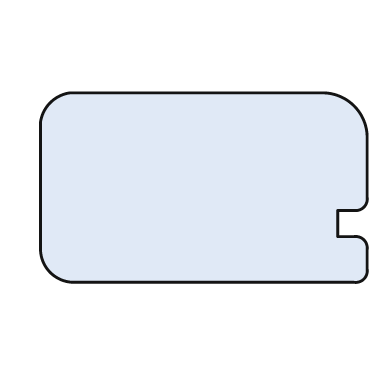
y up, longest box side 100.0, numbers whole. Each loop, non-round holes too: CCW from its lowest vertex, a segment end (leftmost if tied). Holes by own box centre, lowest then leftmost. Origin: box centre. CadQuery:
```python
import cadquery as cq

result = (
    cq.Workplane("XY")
    .moveTo(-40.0, -29.0)
    .lineTo(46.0, -29.0)
    .threePointArc((49.0, -28.0), (50.0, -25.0))
    .lineTo(50.0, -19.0)
    .threePointArc((49.0, -16.0), (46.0, -15.0))
    .lineTo(41.0, -15.0)
    .lineTo(41.0, -7.0)
    .lineTo(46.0, -7.0)
    .threePointArc((49.0, -6.0), (50.0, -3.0))
    .lineTo(50.0, 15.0)
    .threePointArc((46.0, 25.0), (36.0, 29.0))
    .lineTo(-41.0, 29.0)
    .threePointArc((-47.0, 26.0), (-50.0, 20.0))
    .lineTo(-50.0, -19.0)
    .threePointArc((-47.0, -26.0), (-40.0, -29.0))
    .close()
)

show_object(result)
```